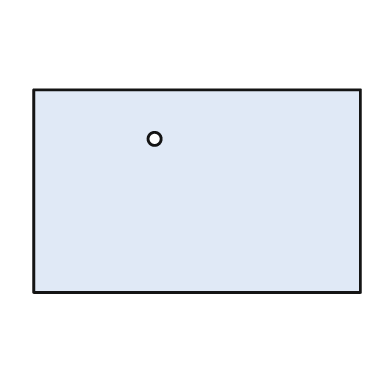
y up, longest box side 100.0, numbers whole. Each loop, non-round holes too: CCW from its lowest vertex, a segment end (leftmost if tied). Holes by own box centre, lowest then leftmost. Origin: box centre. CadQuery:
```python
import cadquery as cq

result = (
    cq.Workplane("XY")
    .moveTo(-50.0, -31.0)
    .lineTo(50.0, -31.0)
    .lineTo(50.0, 31.0)
    .lineTo(-50.0, 31.0)
    .close()
    .moveTo(-13.0, 16.0)
    .circle(2.0)
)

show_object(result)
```